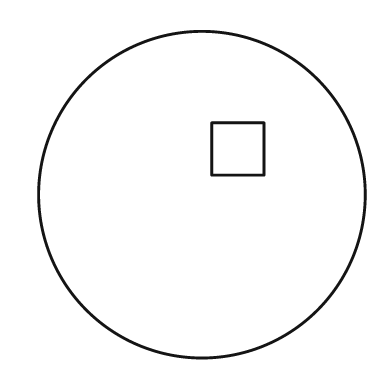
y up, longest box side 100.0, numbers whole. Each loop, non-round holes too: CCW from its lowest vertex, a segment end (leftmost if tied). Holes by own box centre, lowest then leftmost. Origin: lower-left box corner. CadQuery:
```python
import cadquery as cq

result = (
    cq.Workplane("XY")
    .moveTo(50.0, 50.0)
    .circle(50.0)
    .moveTo(53.0, 56.0)
    .lineTo(69.0, 56.0)
    .lineTo(69.0, 72.0)
    .lineTo(53.0, 72.0)
    .close()
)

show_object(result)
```